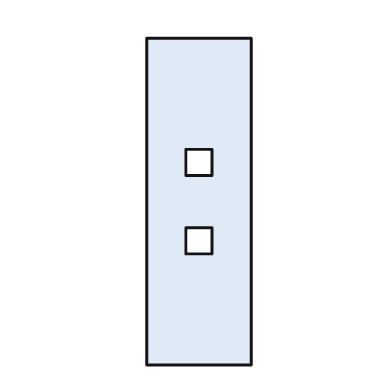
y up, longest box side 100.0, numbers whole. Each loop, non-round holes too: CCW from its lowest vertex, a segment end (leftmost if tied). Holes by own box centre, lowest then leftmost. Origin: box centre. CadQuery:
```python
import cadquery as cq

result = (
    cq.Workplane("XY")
    .moveTo(-16.0, -50.0)
    .lineTo(16.0, -50.0)
    .lineTo(16.0, 50.0)
    .lineTo(-16.0, 50.0)
    .close()
    .moveTo(-4.0, -16.0)
    .lineTo(4.0, -16.0)
    .lineTo(4.0, -8.0)
    .lineTo(-4.0, -8.0)
    .close()
    .moveTo(-4.0, 8.0)
    .lineTo(4.0, 8.0)
    .lineTo(4.0, 16.0)
    .lineTo(-4.0, 16.0)
    .close()
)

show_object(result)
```